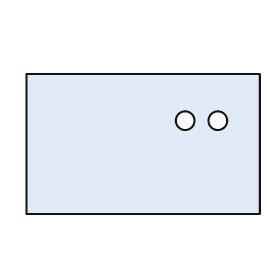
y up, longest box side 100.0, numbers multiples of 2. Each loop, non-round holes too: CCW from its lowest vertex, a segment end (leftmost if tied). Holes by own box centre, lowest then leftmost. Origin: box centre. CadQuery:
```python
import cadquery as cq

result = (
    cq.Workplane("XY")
    .moveTo(-50.0, -30.0)
    .lineTo(50.0, -30.0)
    .lineTo(50.0, 30.0)
    .lineTo(-50.0, 30.0)
    .close()
    .moveTo(18.0, 10.0)
    .circle(4.0)
    .moveTo(32.0, 10.0)
    .circle(4.0)
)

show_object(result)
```